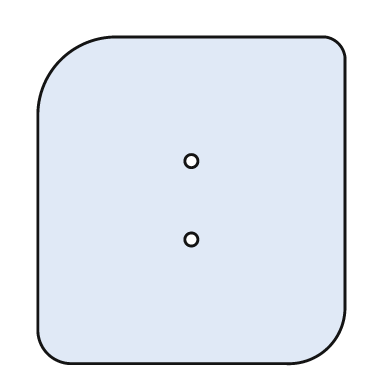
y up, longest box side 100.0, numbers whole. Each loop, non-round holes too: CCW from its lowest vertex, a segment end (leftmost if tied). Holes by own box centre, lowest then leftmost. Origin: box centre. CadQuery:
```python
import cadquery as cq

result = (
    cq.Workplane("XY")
    .moveTo(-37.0, -50.0)
    .lineTo(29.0, -50.0)
    .threePointArc((42.0, -45.0), (47.0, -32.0))
    .lineTo(47.0, 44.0)
    .threePointArc((45.0, 48.0), (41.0, 50.0))
    .lineTo(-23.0, 50.0)
    .threePointArc((-40.0, 43.0), (-47.0, 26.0))
    .lineTo(-47.0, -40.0)
    .threePointArc((-44.0, -47.0), (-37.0, -50.0))
    .close()
    .moveTo(0.0, -12.0)
    .circle(2.0)
    .moveTo(0.0, 12.0)
    .circle(2.0)
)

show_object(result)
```